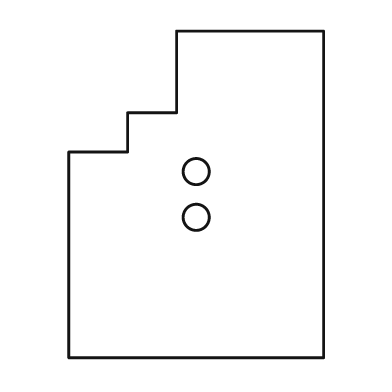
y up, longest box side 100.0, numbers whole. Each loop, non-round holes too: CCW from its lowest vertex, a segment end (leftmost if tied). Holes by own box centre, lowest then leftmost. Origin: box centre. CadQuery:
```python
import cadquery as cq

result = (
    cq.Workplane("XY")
    .moveTo(-39.0, -50.0)
    .lineTo(39.0, -50.0)
    .lineTo(39.0, 50.0)
    .lineTo(-6.0, 50.0)
    .lineTo(-6.0, 25.0)
    .lineTo(-21.0, 25.0)
    .lineTo(-21.0, 13.0)
    .lineTo(-39.0, 13.0)
    .close()
    .moveTo(0.0, -7.0)
    .circle(4.0)
    .moveTo(0.0, 7.0)
    .circle(4.0)
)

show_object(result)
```